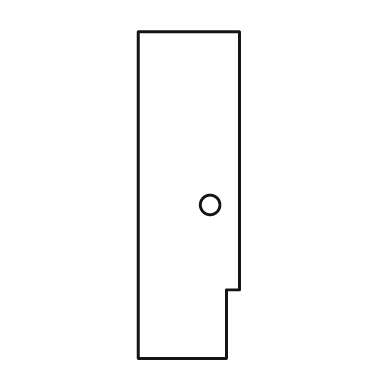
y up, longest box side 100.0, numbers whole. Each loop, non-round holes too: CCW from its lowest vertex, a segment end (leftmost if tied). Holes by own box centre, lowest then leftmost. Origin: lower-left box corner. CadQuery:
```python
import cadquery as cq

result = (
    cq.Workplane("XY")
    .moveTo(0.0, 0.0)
    .lineTo(27.0, 0.0)
    .lineTo(27.0, 21.0)
    .lineTo(31.0, 21.0)
    .lineTo(31.0, 100.0)
    .lineTo(0.0, 100.0)
    .close()
    .moveTo(22.0, 47.0)
    .circle(3.0)
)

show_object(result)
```